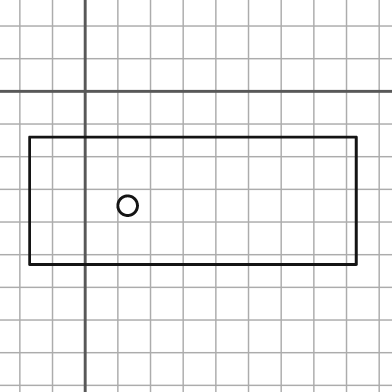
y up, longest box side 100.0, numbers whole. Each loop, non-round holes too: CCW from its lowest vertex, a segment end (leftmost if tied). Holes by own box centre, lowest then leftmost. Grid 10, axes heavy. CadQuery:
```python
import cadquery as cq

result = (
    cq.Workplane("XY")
    .moveTo(-17.0, -53.0)
    .lineTo(83.0, -53.0)
    .lineTo(83.0, -14.0)
    .lineTo(-17.0, -14.0)
    .close()
    .moveTo(13.0, -35.0)
    .circle(3.0)
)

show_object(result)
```